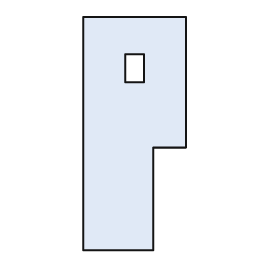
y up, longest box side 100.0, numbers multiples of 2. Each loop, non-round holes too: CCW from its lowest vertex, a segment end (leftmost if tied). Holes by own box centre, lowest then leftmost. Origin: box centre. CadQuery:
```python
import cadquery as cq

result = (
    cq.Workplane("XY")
    .moveTo(-22.0, -50.0)
    .lineTo(8.0, -50.0)
    .lineTo(8.0, -6.0)
    .lineTo(22.0, -6.0)
    .lineTo(22.0, 50.0)
    .lineTo(-22.0, 50.0)
    .close()
    .moveTo(-4.0, 22.0)
    .lineTo(4.0, 22.0)
    .lineTo(4.0, 34.0)
    .lineTo(-4.0, 34.0)
    .close()
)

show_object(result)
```